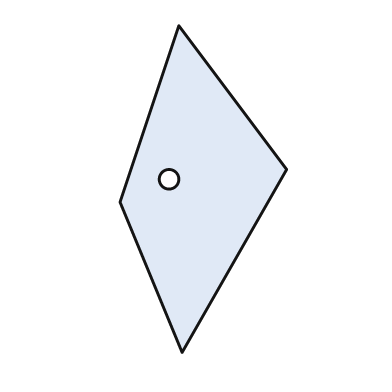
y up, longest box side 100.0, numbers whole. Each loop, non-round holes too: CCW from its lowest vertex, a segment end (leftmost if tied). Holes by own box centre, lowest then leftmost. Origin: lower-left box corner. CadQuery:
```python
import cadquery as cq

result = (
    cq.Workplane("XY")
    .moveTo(19.0, 0.0)
    .lineTo(51.0, 56.0)
    .lineTo(18.0, 100.0)
    .lineTo(0.0, 46.0)
    .close()
    .moveTo(15.0, 53.0)
    .circle(3.0)
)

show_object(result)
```